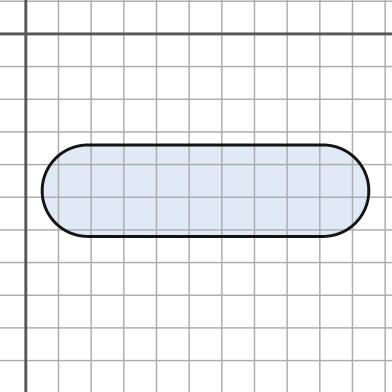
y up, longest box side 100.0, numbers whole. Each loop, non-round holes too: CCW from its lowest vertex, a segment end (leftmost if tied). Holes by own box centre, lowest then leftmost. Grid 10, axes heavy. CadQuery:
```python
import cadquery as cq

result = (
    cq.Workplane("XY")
    .moveTo(19.0, -62.0)
    .lineTo(91.0, -62.0)
    .threePointArc((105.0, -48.0), (91.0, -34.0))
    .lineTo(19.0, -34.0)
    .threePointArc((5.0, -48.0), (19.0, -62.0))
    .close()
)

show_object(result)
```